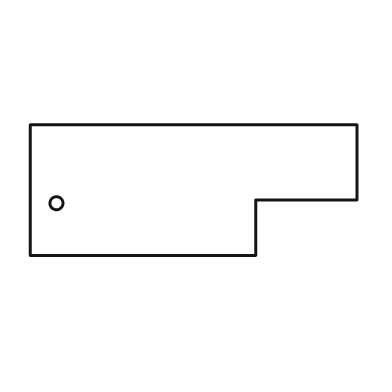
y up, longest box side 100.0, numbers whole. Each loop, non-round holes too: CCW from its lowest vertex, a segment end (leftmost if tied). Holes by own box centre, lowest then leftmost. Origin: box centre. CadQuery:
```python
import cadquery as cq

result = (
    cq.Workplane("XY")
    .moveTo(-50.0, -20.0)
    .lineTo(19.0, -20.0)
    .lineTo(19.0, -3.0)
    .lineTo(50.0, -3.0)
    .lineTo(50.0, 20.0)
    .lineTo(-50.0, 20.0)
    .close()
    .moveTo(-42.0, -4.0)
    .circle(2.0)
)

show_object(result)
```